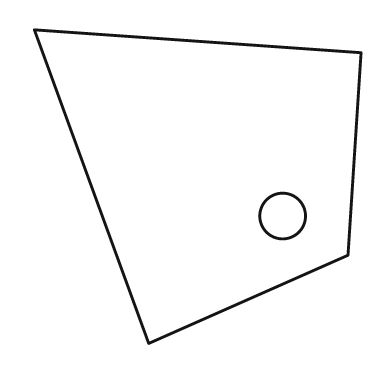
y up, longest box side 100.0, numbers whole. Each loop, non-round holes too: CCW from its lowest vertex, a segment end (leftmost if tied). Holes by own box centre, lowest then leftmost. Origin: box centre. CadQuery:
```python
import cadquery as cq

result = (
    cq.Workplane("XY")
    .moveTo(-15.0, -48.0)
    .lineTo(46.0, -21.0)
    .lineTo(50.0, 41.0)
    .lineTo(-50.0, 48.0)
    .close()
    .moveTo(26.0, -9.0)
    .circle(7.0)
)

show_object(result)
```